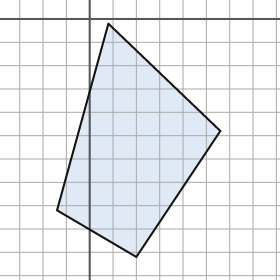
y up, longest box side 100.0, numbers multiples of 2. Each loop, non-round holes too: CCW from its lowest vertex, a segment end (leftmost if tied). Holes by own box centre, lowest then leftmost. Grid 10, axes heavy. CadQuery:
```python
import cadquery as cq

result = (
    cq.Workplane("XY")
    .moveTo(20.0, -102.0)
    .lineTo(56.0, -48.0)
    .lineTo(8.0, -2.0)
    .lineTo(-14.0, -82.0)
    .close()
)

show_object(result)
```